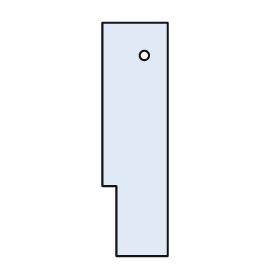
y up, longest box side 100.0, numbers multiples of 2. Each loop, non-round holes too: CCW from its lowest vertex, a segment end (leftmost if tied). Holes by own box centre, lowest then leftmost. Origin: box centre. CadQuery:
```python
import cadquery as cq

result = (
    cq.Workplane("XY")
    .moveTo(-8.0, -50.0)
    .lineTo(14.0, -50.0)
    .lineTo(14.0, 50.0)
    .lineTo(-14.0, 50.0)
    .lineTo(-14.0, -20.0)
    .lineTo(-8.0, -20.0)
    .close()
    .moveTo(4.0, 36.0)
    .circle(2.0)
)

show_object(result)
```